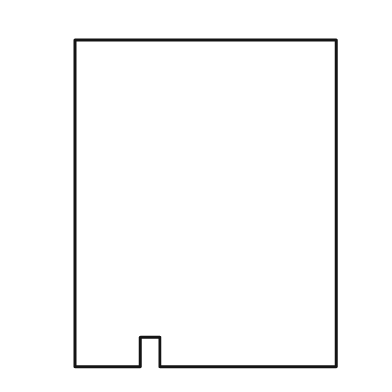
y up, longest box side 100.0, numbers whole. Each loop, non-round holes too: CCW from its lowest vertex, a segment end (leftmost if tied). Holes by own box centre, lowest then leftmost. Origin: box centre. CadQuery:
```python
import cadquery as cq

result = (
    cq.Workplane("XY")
    .moveTo(-40.0, -50.0)
    .lineTo(-20.0, -50.0)
    .lineTo(-20.0, -41.0)
    .lineTo(-14.0, -41.0)
    .lineTo(-14.0, -50.0)
    .lineTo(40.0, -50.0)
    .lineTo(40.0, 50.0)
    .lineTo(-40.0, 50.0)
    .close()
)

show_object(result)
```